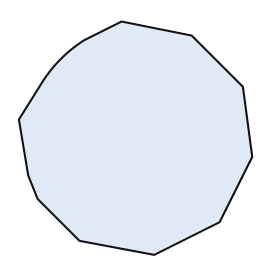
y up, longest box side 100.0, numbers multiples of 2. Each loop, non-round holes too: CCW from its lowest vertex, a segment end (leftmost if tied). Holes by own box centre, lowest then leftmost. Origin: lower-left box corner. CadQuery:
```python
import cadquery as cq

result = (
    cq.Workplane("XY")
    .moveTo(58.0, 0.0)
    .lineTo(86.0, 14.0)
    .lineTo(100.0, 42.0)
    .lineTo(96.0, 72.0)
    .lineTo(74.0, 94.0)
    .lineTo(44.0, 100.0)
    .lineTo(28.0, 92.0)
    .threePointArc((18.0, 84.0), (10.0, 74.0))
    .lineTo(0.0, 58.0)
    .lineTo(4.0, 34.0)
    .lineTo(8.0, 24.0)
    .lineTo(26.0, 6.0)
    .close()
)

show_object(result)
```